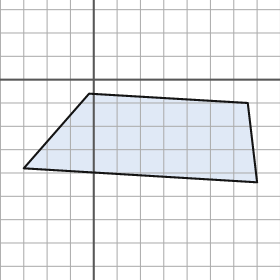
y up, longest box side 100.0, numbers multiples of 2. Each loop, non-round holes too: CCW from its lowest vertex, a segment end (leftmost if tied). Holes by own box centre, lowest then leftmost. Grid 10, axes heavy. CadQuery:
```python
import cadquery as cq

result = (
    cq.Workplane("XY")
    .moveTo(70.0, -44.0)
    .lineTo(66.0, -10.0)
    .lineTo(-2.0, -6.0)
    .lineTo(-30.0, -38.0)
    .close()
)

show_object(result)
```